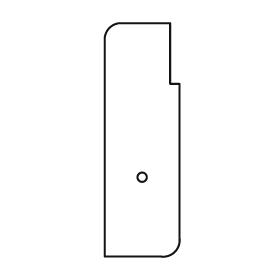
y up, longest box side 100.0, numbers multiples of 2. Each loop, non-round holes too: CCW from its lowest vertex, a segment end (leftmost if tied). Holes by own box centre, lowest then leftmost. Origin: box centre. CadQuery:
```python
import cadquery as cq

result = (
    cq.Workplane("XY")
    .moveTo(-16.0, -50.0)
    .lineTo(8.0, -50.0)
    .threePointArc((14.0, -48.0), (16.0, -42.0))
    .lineTo(16.0, 24.0)
    .lineTo(12.0, 24.0)
    .lineTo(12.0, 50.0)
    .lineTo(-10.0, 50.0)
    .threePointArc((-14.0, 48.0), (-16.0, 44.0))
    .close()
    .moveTo(0.0, -16.0)
    .circle(2.0)
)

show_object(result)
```